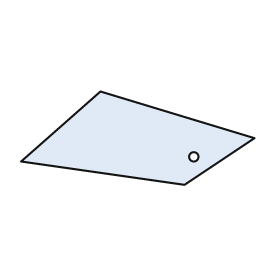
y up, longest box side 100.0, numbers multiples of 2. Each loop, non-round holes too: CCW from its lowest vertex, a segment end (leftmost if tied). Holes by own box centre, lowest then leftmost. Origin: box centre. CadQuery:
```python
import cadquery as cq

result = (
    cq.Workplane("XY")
    .moveTo(20.0, -20.0)
    .lineTo(50.0, 0.0)
    .lineTo(-16.0, 20.0)
    .lineTo(-50.0, -10.0)
    .close()
    .moveTo(24.0, -8.0)
    .circle(2.0)
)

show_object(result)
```